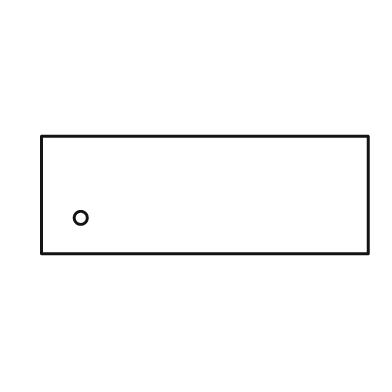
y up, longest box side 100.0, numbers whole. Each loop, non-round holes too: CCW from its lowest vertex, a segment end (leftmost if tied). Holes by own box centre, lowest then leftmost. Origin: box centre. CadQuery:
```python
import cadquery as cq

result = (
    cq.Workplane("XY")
    .moveTo(-50.0, -18.0)
    .lineTo(50.0, -18.0)
    .lineTo(50.0, 18.0)
    .lineTo(-50.0, 18.0)
    .close()
    .moveTo(-38.0, -7.0)
    .circle(2.0)
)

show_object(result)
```